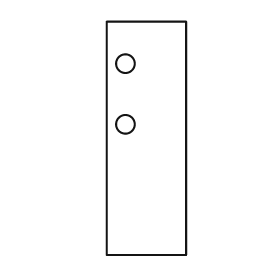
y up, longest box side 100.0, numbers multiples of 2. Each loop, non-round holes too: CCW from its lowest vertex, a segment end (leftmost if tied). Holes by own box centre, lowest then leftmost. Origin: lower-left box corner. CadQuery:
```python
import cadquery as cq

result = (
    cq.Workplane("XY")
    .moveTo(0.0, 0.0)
    .lineTo(34.0, 0.0)
    .lineTo(34.0, 100.0)
    .lineTo(0.0, 100.0)
    .close()
    .moveTo(8.0, 56.0)
    .circle(4.0)
    .moveTo(8.0, 82.0)
    .circle(4.0)
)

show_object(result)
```